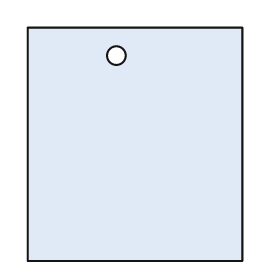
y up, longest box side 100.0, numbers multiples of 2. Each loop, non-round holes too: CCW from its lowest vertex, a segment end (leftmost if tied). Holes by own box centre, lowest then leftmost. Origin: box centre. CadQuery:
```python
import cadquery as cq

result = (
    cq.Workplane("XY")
    .moveTo(-46.0, -50.0)
    .lineTo(46.0, -50.0)
    .lineTo(46.0, 50.0)
    .lineTo(-46.0, 50.0)
    .close()
    .moveTo(-8.0, 38.0)
    .circle(4.0)
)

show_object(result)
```